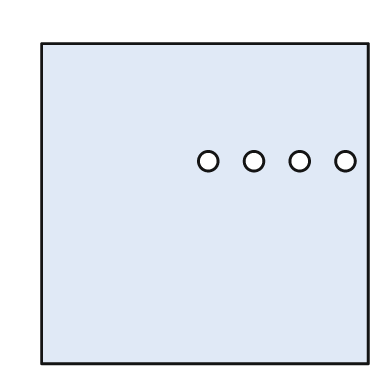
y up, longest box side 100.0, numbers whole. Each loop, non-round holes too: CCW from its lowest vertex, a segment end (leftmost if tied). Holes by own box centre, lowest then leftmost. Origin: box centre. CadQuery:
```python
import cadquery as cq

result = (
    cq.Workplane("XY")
    .moveTo(-50.0, -49.0)
    .lineTo(50.0, -49.0)
    .lineTo(50.0, 49.0)
    .lineTo(-50.0, 49.0)
    .close()
    .moveTo(1.0, 13.0)
    .circle(3.0)
    .moveTo(15.0, 13.0)
    .circle(3.0)
    .moveTo(29.0, 13.0)
    .circle(3.0)
    .moveTo(43.0, 13.0)
    .circle(3.0)
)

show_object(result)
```